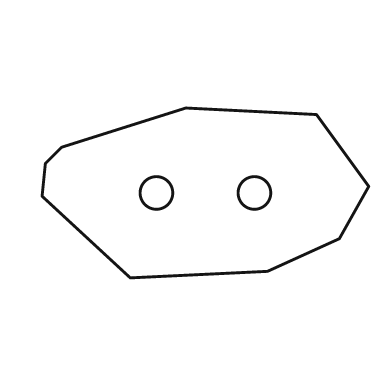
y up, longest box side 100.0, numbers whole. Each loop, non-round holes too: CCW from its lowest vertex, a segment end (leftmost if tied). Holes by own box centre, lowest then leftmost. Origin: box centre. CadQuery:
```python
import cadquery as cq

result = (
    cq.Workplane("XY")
    .moveTo(-23.0, -26.0)
    .lineTo(19.0, -24.0)
    .lineTo(41.0, -14.0)
    .lineTo(50.0, 2.0)
    .lineTo(34.0, 24.0)
    .lineTo(-6.0, 26.0)
    .lineTo(-44.0, 14.0)
    .lineTo(-49.0, 9.0)
    .lineTo(-50.0, -1.0)
    .close()
    .moveTo(-15.0, 0.0)
    .circle(5.0)
    .moveTo(15.0, 0.0)
    .circle(5.0)
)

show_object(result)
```